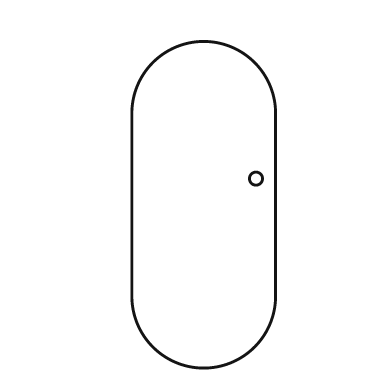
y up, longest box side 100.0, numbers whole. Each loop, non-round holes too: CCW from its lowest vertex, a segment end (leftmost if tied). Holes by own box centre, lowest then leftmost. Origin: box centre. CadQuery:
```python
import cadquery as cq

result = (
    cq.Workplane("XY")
    .moveTo(-22.0, -28.0)
    .threePointArc((0.0, -50.0), (22.0, -28.0))
    .lineTo(22.0, 28.0)
    .threePointArc((0.0, 50.0), (-22.0, 28.0))
    .close()
    .moveTo(16.0, 8.0)
    .circle(2.0)
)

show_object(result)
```